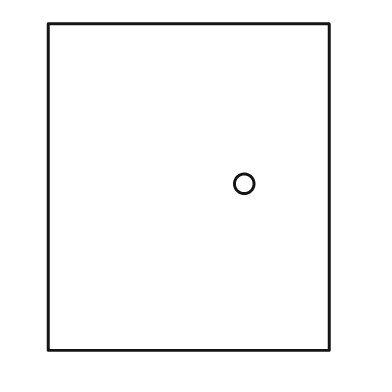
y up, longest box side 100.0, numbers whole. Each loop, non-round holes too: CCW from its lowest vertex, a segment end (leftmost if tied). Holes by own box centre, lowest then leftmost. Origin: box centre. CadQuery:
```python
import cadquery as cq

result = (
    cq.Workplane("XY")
    .moveTo(-43.0, -50.0)
    .lineTo(43.0, -50.0)
    .lineTo(43.0, 50.0)
    .lineTo(-43.0, 50.0)
    .close()
    .moveTo(17.0, 1.0)
    .circle(3.0)
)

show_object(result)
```